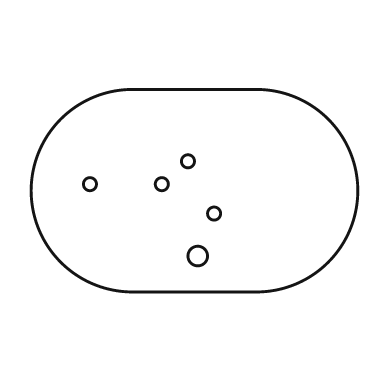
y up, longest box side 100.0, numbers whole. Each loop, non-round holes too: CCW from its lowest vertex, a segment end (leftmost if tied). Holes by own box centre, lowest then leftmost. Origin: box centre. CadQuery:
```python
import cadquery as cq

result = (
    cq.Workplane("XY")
    .moveTo(-19.0, -31.0)
    .lineTo(19.0, -31.0)
    .threePointArc((50.0, 0.0), (19.0, 31.0))
    .lineTo(-19.0, 31.0)
    .threePointArc((-50.0, 0.0), (-19.0, -31.0))
    .close()
    .moveTo(1.0, -20.0)
    .circle(3.0)
    .moveTo(6.0, -7.0)
    .circle(2.0)
    .moveTo(-32.0, 2.0)
    .circle(2.0)
    .moveTo(-10.0, 2.0)
    .circle(2.0)
    .moveTo(-2.0, 9.0)
    .circle(2.0)
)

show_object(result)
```